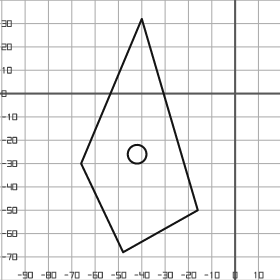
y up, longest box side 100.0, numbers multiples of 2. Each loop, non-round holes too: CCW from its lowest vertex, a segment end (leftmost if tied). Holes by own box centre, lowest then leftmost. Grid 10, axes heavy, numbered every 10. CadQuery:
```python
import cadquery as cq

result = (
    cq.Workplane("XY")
    .moveTo(-48.0, -68.0)
    .lineTo(-16.0, -50.0)
    .lineTo(-40.0, 32.0)
    .lineTo(-66.0, -30.0)
    .close()
    .moveTo(-42.0, -26.0)
    .circle(4.0)
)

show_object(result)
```